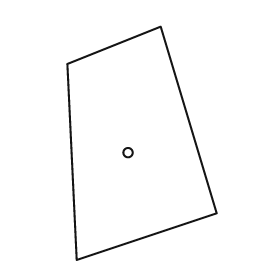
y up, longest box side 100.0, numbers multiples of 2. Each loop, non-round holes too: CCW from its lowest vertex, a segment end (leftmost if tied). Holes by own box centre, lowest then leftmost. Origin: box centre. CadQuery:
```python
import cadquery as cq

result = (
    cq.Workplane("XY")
    .moveTo(-28.0, -50.0)
    .lineTo(32.0, -30.0)
    .lineTo(8.0, 50.0)
    .lineTo(-32.0, 34.0)
    .close()
    .moveTo(-6.0, -4.0)
    .circle(2.0)
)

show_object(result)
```